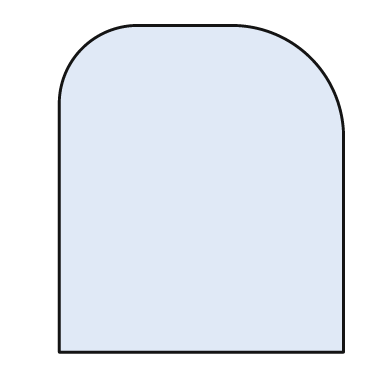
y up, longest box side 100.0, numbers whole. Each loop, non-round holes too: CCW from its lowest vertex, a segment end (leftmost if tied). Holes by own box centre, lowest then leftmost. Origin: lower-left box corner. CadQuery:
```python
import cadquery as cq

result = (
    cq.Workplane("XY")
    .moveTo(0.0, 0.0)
    .lineTo(87.0, 0.0)
    .lineTo(87.0, 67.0)
    .threePointArc((77.0, 90.0), (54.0, 100.0))
    .lineTo(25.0, 100.0)
    .threePointArc((7.0, 93.0), (0.0, 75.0))
    .close()
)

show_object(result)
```